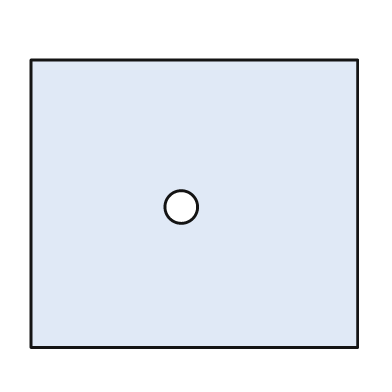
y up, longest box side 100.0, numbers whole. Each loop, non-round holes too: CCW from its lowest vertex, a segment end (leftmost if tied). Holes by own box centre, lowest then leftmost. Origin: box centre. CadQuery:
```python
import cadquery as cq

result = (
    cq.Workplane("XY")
    .moveTo(-50.0, -44.0)
    .lineTo(50.0, -44.0)
    .lineTo(50.0, 44.0)
    .lineTo(-50.0, 44.0)
    .close()
    .moveTo(-4.0, -1.0)
    .circle(5.0)
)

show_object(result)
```